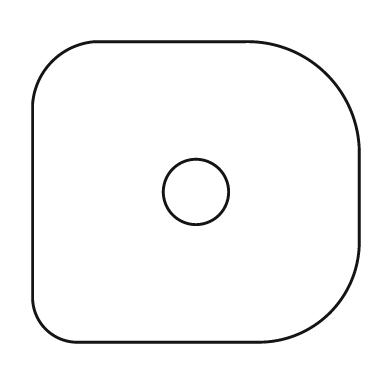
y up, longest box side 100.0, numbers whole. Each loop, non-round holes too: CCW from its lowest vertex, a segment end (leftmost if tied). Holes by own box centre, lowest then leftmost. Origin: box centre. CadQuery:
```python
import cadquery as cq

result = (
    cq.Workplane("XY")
    .moveTo(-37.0, -46.0)
    .lineTo(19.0, -46.0)
    .threePointArc((41.0, -37.0), (50.0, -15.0))
    .lineTo(50.0, 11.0)
    .threePointArc((40.0, 36.0), (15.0, 46.0))
    .lineTo(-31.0, 46.0)
    .threePointArc((-44.0, 40.0), (-50.0, 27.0))
    .lineTo(-50.0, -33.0)
    .threePointArc((-46.0, -42.0), (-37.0, -46.0))
    .close()
    .moveTo(0.0, 0.0)
    .circle(10.0)
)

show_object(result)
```